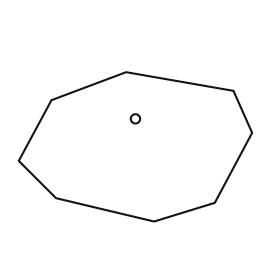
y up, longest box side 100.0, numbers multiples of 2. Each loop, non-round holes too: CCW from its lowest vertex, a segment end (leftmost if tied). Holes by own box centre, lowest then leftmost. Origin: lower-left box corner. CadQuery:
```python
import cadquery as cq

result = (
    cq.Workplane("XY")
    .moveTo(58.0, 0.0)
    .lineTo(84.0, 8.0)
    .lineTo(100.0, 38.0)
    .lineTo(92.0, 56.0)
    .lineTo(46.0, 64.0)
    .lineTo(14.0, 52.0)
    .lineTo(0.0, 26.0)
    .lineTo(16.0, 10.0)
    .close()
    .moveTo(50.0, 44.0)
    .circle(2.0)
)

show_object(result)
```